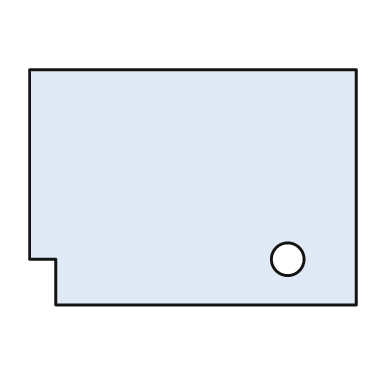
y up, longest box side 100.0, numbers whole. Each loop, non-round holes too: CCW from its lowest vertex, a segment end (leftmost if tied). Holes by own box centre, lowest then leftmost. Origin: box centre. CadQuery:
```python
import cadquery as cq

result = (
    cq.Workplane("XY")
    .moveTo(-42.0, -36.0)
    .lineTo(50.0, -36.0)
    .lineTo(50.0, 36.0)
    .lineTo(-50.0, 36.0)
    .lineTo(-50.0, -22.0)
    .lineTo(-42.0, -22.0)
    .close()
    .moveTo(29.0, -22.0)
    .circle(5.0)
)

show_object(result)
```